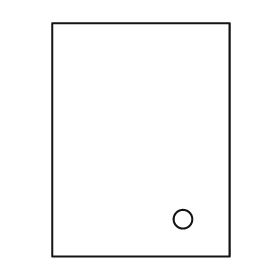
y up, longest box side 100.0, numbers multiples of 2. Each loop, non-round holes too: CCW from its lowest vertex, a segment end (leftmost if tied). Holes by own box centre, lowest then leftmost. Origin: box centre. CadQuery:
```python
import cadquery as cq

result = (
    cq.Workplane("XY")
    .moveTo(-38.0, -50.0)
    .lineTo(38.0, -50.0)
    .lineTo(38.0, 50.0)
    .lineTo(-38.0, 50.0)
    .close()
    .moveTo(18.0, -34.0)
    .circle(4.0)
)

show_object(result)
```